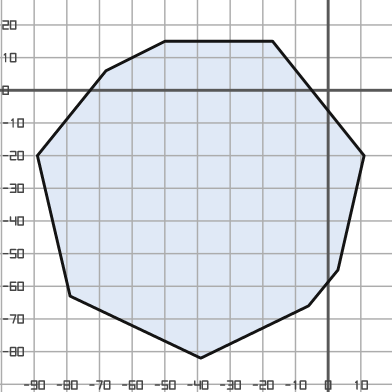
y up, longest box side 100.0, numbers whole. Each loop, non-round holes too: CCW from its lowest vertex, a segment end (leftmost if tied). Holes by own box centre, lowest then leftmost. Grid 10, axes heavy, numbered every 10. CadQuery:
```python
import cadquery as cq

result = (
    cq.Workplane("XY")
    .moveTo(-39.0, -82.0)
    .lineTo(-6.0, -66.0)
    .lineTo(3.0, -55.0)
    .lineTo(11.0, -20.0)
    .lineTo(-17.0, 15.0)
    .lineTo(-50.0, 15.0)
    .lineTo(-68.0, 6.0)
    .lineTo(-89.0, -20.0)
    .lineTo(-79.0, -63.0)
    .close()
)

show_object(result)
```